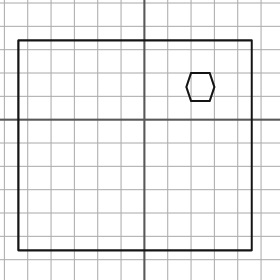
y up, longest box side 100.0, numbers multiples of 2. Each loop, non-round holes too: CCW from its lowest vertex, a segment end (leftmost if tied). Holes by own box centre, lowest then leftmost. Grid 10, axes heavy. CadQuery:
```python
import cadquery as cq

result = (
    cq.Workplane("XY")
    .moveTo(-54.0, -56.0)
    .lineTo(46.0, -56.0)
    .lineTo(46.0, 34.0)
    .lineTo(-54.0, 34.0)
    .close()
    .moveTo(20.0, 8.0)
    .lineTo(28.0, 8.0)
    .lineTo(30.0, 14.0)
    .lineTo(28.0, 20.0)
    .lineTo(20.0, 20.0)
    .lineTo(18.0, 14.0)
    .close()
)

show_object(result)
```